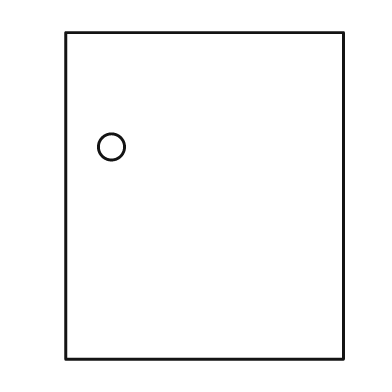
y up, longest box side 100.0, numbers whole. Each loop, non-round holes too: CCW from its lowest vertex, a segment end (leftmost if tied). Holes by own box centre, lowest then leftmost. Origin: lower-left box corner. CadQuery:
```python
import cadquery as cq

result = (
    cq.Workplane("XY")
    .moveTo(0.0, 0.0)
    .lineTo(85.0, 0.0)
    .lineTo(85.0, 100.0)
    .lineTo(0.0, 100.0)
    .close()
    .moveTo(14.0, 65.0)
    .circle(4.0)
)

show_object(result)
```